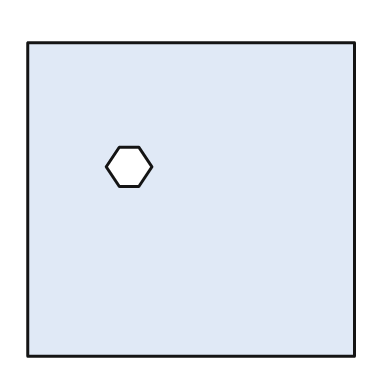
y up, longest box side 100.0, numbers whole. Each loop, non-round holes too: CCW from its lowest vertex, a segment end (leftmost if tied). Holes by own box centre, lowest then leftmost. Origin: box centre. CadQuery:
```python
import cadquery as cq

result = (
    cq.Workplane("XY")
    .moveTo(-50.0, -48.0)
    .lineTo(50.0, -48.0)
    .lineTo(50.0, 48.0)
    .lineTo(-50.0, 48.0)
    .close()
    .moveTo(-22.0, 4.0)
    .lineTo(-16.0, 4.0)
    .lineTo(-12.0, 10.0)
    .lineTo(-16.0, 16.0)
    .lineTo(-22.0, 16.0)
    .lineTo(-26.0, 10.0)
    .close()
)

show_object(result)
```